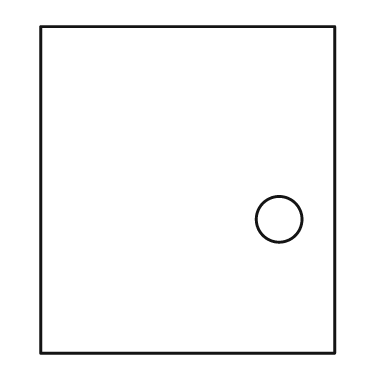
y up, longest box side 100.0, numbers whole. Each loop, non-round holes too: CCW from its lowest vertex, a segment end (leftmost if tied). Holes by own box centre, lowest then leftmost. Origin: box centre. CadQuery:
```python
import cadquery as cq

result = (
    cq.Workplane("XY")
    .moveTo(-45.0, -50.0)
    .lineTo(45.0, -50.0)
    .lineTo(45.0, 50.0)
    .lineTo(-45.0, 50.0)
    .close()
    .moveTo(28.0, -9.0)
    .circle(7.0)
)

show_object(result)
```